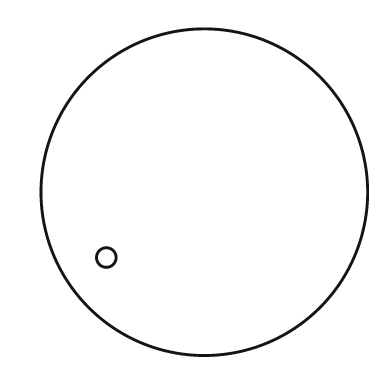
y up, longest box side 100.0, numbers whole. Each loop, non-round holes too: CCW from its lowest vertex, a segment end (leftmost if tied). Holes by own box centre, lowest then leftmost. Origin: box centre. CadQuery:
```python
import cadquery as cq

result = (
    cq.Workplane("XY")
    .moveTo(0.0, 0.0)
    .circle(50.0)
    .moveTo(-30.0, -20.0)
    .circle(3.0)
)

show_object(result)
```